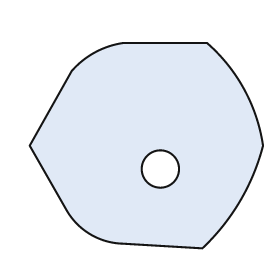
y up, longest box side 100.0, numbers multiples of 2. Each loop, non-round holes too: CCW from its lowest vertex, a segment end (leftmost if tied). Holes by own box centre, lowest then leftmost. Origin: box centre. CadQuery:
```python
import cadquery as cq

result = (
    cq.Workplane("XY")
    .moveTo(24.0, -44.0)
    .threePointArc((40.0, -24.0), (50.0, 0.0))
    .threePointArc((42.0, 24.0), (26.0, 44.0))
    .lineTo(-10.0, 44.0)
    .threePointArc((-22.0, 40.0), (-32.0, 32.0))
    .lineTo(-50.0, 0.0)
    .lineTo(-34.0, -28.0)
    .threePointArc((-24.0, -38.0), (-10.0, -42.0))
    .close()
    .moveTo(6.0, -10.0)
    .circle(8.0)
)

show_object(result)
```